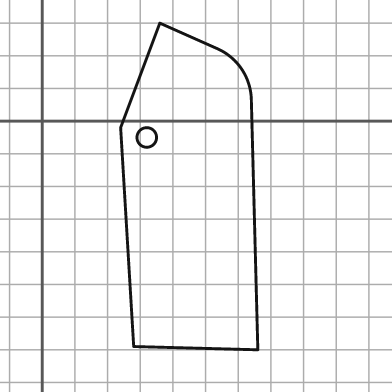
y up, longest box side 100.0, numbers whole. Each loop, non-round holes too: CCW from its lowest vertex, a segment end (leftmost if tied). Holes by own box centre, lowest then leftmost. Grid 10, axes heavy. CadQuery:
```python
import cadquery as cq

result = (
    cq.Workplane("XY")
    .moveTo(66.0, -70.0)
    .lineTo(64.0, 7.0)
    .threePointArc((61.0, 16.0), (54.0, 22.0))
    .lineTo(36.0, 30.0)
    .lineTo(24.0, -2.0)
    .lineTo(28.0, -69.0)
    .close()
    .moveTo(32.0, -5.0)
    .circle(3.0)
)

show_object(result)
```